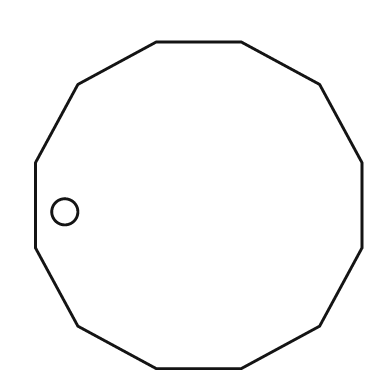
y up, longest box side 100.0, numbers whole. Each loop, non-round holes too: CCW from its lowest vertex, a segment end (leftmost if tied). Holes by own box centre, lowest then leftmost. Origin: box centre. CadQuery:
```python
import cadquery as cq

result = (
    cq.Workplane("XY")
    .moveTo(-13.0, -50.0)
    .lineTo(13.0, -50.0)
    .lineTo(37.0, -37.0)
    .lineTo(50.0, -13.0)
    .lineTo(50.0, 13.0)
    .lineTo(37.0, 37.0)
    .lineTo(13.0, 50.0)
    .lineTo(-13.0, 50.0)
    .lineTo(-37.0, 37.0)
    .lineTo(-50.0, 13.0)
    .lineTo(-50.0, -13.0)
    .lineTo(-37.0, -37.0)
    .close()
    .moveTo(-41.0, -2.0)
    .circle(4.0)
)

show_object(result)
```